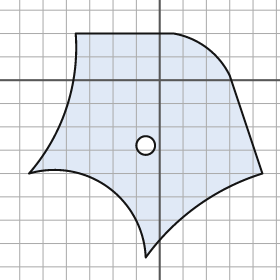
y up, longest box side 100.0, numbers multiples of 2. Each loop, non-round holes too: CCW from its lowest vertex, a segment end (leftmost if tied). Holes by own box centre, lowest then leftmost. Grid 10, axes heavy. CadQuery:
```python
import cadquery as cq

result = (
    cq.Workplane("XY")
    .moveTo(-6.0, -76.0)
    .threePointArc((16.0, -54.0), (44.0, -40.0))
    .lineTo(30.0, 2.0)
    .threePointArc((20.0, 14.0), (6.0, 20.0))
    .lineTo(-36.0, 20.0)
    .threePointArc((-40.0, -12.0), (-56.0, -40.0))
    .threePointArc((-22.0, -46.0), (-6.0, -76.0))
    .close()
    .moveTo(-6.0, -28.0)
    .circle(4.0)
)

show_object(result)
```